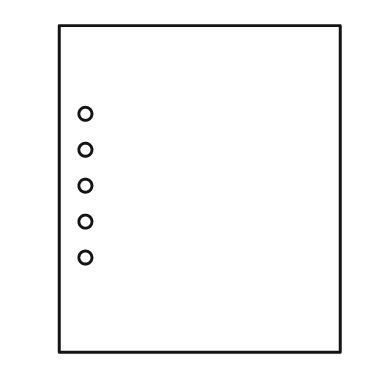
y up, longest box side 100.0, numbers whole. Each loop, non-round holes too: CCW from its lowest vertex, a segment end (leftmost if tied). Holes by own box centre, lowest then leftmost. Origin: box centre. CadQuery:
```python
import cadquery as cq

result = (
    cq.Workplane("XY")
    .moveTo(-43.0, -50.0)
    .lineTo(43.0, -50.0)
    .lineTo(43.0, 50.0)
    .lineTo(-43.0, 50.0)
    .close()
    .moveTo(-35.0, -21.0)
    .circle(2.0)
    .moveTo(-35.0, -10.0)
    .circle(2.0)
    .moveTo(-35.0, 1.0)
    .circle(2.0)
    .moveTo(-35.0, 12.0)
    .circle(2.0)
    .moveTo(-35.0, 23.0)
    .circle(2.0)
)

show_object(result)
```